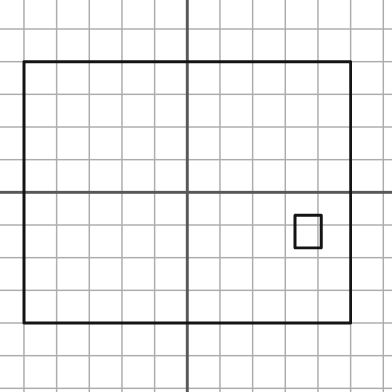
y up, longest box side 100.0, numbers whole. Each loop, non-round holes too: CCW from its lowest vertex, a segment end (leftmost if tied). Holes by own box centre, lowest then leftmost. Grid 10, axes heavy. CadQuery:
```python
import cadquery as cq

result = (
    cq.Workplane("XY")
    .moveTo(-50.0, -40.0)
    .lineTo(50.0, -40.0)
    .lineTo(50.0, 40.0)
    .lineTo(-50.0, 40.0)
    .close()
    .moveTo(33.0, -17.0)
    .lineTo(41.0, -17.0)
    .lineTo(41.0, -7.0)
    .lineTo(33.0, -7.0)
    .close()
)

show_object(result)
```